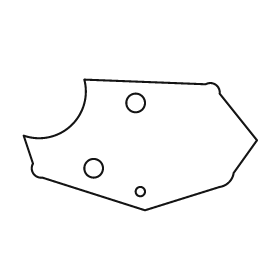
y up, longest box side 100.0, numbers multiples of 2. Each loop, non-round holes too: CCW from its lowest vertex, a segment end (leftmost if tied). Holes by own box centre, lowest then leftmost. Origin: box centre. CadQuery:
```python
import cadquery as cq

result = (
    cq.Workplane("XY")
    .moveTo(2.0, -28.0)
    .lineTo(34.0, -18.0)
    .threePointArc((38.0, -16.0), (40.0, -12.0))
    .lineTo(50.0, 2.0)
    .lineTo(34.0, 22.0)
    .threePointArc((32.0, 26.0), (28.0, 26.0))
    .lineTo(-24.0, 28.0)
    .threePointArc((-30.0, 8.0), (-50.0, 4.0))
    .lineTo(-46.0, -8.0)
    .threePointArc((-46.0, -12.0), (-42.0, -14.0))
    .close()
    .moveTo(0.0, -20.0)
    .circle(2.0)
    .moveTo(-20.0, -10.0)
    .circle(4.0)
    .moveTo(-2.0, 18.0)
    .circle(4.0)
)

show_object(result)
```